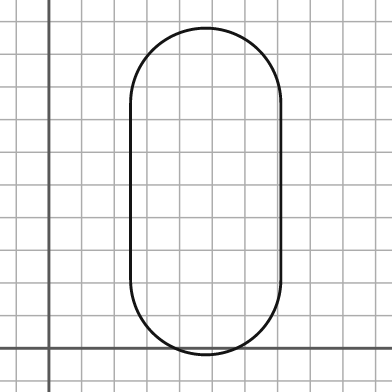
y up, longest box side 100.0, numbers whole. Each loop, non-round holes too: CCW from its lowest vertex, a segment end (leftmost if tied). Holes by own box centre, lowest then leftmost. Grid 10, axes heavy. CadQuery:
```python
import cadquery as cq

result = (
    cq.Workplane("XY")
    .moveTo(25.0, 21.0)
    .threePointArc((48.0, -2.0), (71.0, 21.0))
    .lineTo(71.0, 75.0)
    .threePointArc((48.0, 98.0), (25.0, 75.0))
    .close()
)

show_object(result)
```